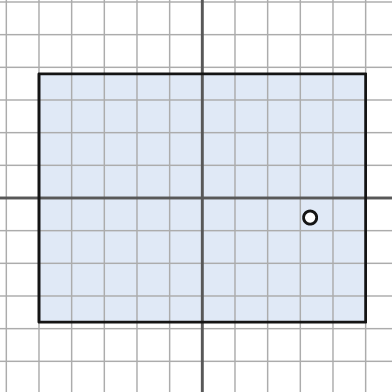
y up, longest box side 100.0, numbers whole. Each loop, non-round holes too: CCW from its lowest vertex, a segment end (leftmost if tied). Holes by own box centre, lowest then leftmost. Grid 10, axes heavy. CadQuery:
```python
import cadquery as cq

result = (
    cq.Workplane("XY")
    .moveTo(-50.0, -38.0)
    .lineTo(50.0, -38.0)
    .lineTo(50.0, 38.0)
    .lineTo(-50.0, 38.0)
    .close()
    .moveTo(33.0, -6.0)
    .circle(2.0)
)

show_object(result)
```